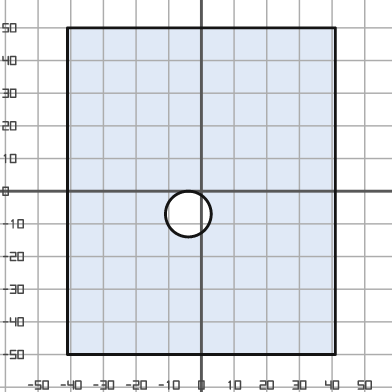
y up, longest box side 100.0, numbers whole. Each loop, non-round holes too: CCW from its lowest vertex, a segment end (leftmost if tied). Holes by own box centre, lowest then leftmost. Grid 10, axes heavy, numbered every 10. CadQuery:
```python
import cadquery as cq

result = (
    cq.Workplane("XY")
    .moveTo(-41.0, -50.0)
    .lineTo(41.0, -50.0)
    .lineTo(41.0, 50.0)
    .lineTo(-41.0, 50.0)
    .close()
    .moveTo(-4.0, -7.0)
    .circle(7.0)
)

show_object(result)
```